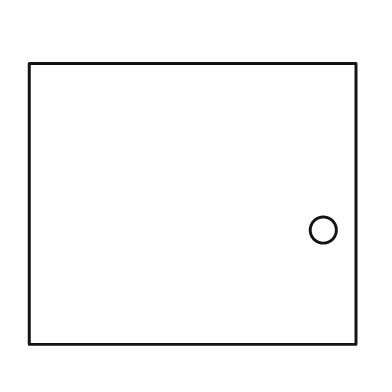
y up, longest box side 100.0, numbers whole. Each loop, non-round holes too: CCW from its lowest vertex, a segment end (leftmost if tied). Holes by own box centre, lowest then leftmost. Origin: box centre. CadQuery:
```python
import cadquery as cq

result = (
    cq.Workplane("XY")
    .moveTo(-50.0, -43.0)
    .lineTo(50.0, -43.0)
    .lineTo(50.0, 43.0)
    .lineTo(-50.0, 43.0)
    .close()
    .moveTo(40.0, -8.0)
    .circle(4.0)
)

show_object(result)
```